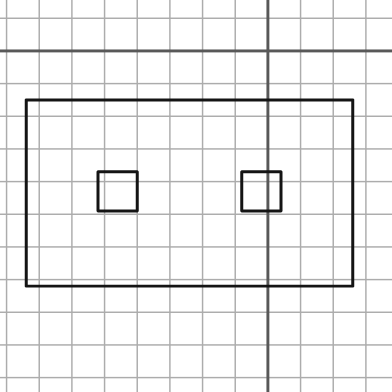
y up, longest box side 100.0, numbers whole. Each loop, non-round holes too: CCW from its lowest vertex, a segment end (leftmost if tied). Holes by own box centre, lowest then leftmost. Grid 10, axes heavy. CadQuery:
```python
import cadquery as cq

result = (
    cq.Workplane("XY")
    .moveTo(-74.0, -72.0)
    .lineTo(26.0, -72.0)
    .lineTo(26.0, -15.0)
    .lineTo(-74.0, -15.0)
    .close()
    .moveTo(-52.0, -49.0)
    .lineTo(-40.0, -49.0)
    .lineTo(-40.0, -37.0)
    .lineTo(-52.0, -37.0)
    .close()
    .moveTo(-8.0, -49.0)
    .lineTo(4.0, -49.0)
    .lineTo(4.0, -37.0)
    .lineTo(-8.0, -37.0)
    .close()
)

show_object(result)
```